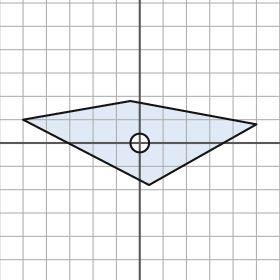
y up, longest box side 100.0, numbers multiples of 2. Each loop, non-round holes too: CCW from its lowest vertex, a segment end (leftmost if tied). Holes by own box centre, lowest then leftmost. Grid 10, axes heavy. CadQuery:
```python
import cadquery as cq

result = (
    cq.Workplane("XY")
    .moveTo(4.0, -18.0)
    .lineTo(50.0, 8.0)
    .lineTo(-4.0, 18.0)
    .lineTo(-50.0, 10.0)
    .close()
    .moveTo(0.0, 0.0)
    .circle(4.0)
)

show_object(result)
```